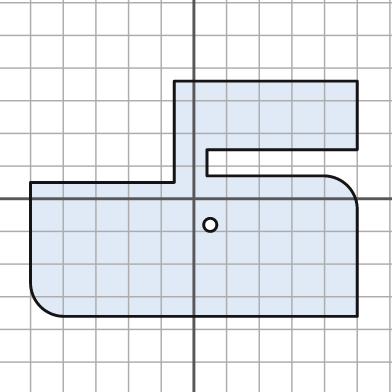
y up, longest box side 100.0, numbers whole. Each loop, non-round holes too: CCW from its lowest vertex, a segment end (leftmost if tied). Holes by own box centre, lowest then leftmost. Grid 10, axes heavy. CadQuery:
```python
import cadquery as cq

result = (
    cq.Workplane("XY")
    .moveTo(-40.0, -36.0)
    .lineTo(50.0, -36.0)
    .lineTo(50.0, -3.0)
    .threePointArc((47.0, 4.0), (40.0, 7.0))
    .lineTo(4.0, 7.0)
    .lineTo(4.0, 15.0)
    .lineTo(50.0, 15.0)
    .lineTo(50.0, 36.0)
    .lineTo(-6.0, 36.0)
    .lineTo(-6.0, 5.0)
    .lineTo(-50.0, 5.0)
    .lineTo(-50.0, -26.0)
    .threePointArc((-47.0, -33.0), (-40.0, -36.0))
    .close()
    .moveTo(5.0, -8.0)
    .circle(2.0)
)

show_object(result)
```